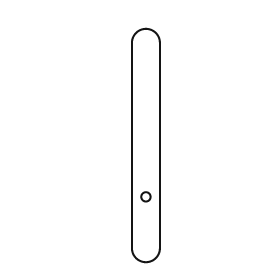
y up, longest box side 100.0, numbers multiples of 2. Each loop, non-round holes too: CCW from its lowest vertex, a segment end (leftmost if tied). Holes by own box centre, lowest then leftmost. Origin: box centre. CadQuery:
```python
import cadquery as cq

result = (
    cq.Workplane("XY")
    .moveTo(-6.0, -44.0)
    .threePointArc((0.0, -50.0), (6.0, -44.0))
    .lineTo(6.0, 44.0)
    .threePointArc((0.0, 50.0), (-6.0, 44.0))
    .close()
    .moveTo(0.0, -22.0)
    .circle(2.0)
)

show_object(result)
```